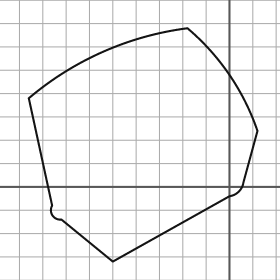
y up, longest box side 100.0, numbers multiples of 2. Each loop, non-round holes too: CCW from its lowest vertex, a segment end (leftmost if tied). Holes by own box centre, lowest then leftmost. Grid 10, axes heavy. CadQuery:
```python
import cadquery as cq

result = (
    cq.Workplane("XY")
    .moveTo(-50.0, -32.0)
    .lineTo(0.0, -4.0)
    .threePointArc((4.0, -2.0), (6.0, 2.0))
    .lineTo(12.0, 24.0)
    .threePointArc((0.0, 48.0), (-18.0, 68.0))
    .threePointArc((-54.0, 58.0), (-86.0, 38.0))
    .lineTo(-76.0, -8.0)
    .threePointArc((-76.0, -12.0), (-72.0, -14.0))
    .close()
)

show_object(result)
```